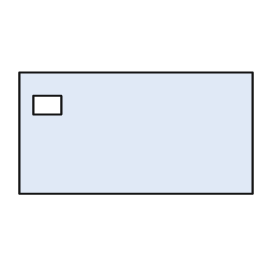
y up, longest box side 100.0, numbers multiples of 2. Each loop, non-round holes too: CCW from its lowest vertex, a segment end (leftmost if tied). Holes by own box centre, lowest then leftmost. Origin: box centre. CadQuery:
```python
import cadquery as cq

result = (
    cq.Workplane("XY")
    .moveTo(-50.0, -26.0)
    .lineTo(50.0, -26.0)
    .lineTo(50.0, 26.0)
    .lineTo(-50.0, 26.0)
    .close()
    .moveTo(-44.0, 8.0)
    .lineTo(-32.0, 8.0)
    .lineTo(-32.0, 16.0)
    .lineTo(-44.0, 16.0)
    .close()
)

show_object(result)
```